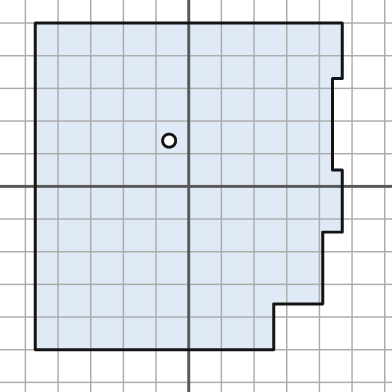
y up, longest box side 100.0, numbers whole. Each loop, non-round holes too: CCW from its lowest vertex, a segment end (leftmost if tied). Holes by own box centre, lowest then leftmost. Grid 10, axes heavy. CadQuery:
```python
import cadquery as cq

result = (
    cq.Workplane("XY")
    .moveTo(-47.0, -50.0)
    .lineTo(26.0, -50.0)
    .lineTo(26.0, -36.0)
    .lineTo(41.0, -36.0)
    .lineTo(41.0, -14.0)
    .lineTo(47.0, -14.0)
    .lineTo(47.0, 5.0)
    .lineTo(44.0, 5.0)
    .lineTo(44.0, 33.0)
    .lineTo(47.0, 33.0)
    .lineTo(47.0, 50.0)
    .lineTo(-47.0, 50.0)
    .close()
    .moveTo(-6.0, 14.0)
    .circle(2.0)
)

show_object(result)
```